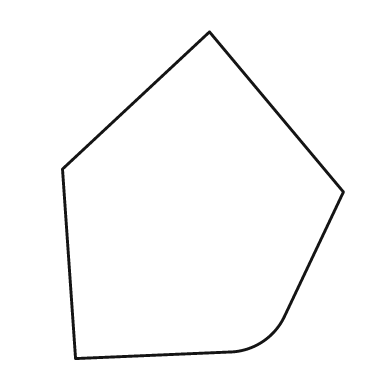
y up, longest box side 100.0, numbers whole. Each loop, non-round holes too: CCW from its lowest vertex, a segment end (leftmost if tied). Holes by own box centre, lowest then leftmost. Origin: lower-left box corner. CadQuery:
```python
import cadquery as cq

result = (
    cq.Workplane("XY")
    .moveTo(4.0, 0.0)
    .lineTo(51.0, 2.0)
    .threePointArc((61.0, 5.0), (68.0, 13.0))
    .lineTo(86.0, 51.0)
    .lineTo(45.0, 100.0)
    .lineTo(0.0, 58.0)
    .close()
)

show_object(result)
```